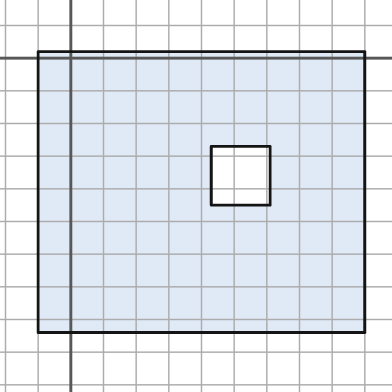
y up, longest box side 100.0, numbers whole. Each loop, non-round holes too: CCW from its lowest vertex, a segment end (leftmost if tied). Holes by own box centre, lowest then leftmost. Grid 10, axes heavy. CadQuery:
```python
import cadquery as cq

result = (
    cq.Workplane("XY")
    .moveTo(-10.0, -84.0)
    .lineTo(90.0, -84.0)
    .lineTo(90.0, 2.0)
    .lineTo(-10.0, 2.0)
    .close()
    .moveTo(43.0, -45.0)
    .lineTo(61.0, -45.0)
    .lineTo(61.0, -27.0)
    .lineTo(43.0, -27.0)
    .close()
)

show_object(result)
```